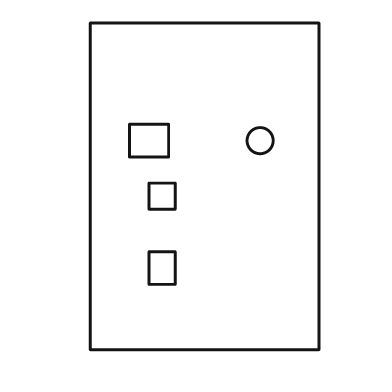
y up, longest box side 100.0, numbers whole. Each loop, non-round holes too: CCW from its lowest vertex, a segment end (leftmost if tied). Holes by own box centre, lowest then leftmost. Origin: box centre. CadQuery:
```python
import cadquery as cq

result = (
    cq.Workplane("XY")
    .moveTo(-35.0, -50.0)
    .lineTo(35.0, -50.0)
    .lineTo(35.0, 50.0)
    .lineTo(-35.0, 50.0)
    .close()
    .moveTo(-17.0, -30.0)
    .lineTo(-9.0, -30.0)
    .lineTo(-9.0, -20.0)
    .lineTo(-17.0, -20.0)
    .close()
    .moveTo(-17.0, -7.0)
    .lineTo(-9.0, -7.0)
    .lineTo(-9.0, 1.0)
    .lineTo(-17.0, 1.0)
    .close()
    .moveTo(-23.0, 9.0)
    .lineTo(-11.0, 9.0)
    .lineTo(-11.0, 19.0)
    .lineTo(-23.0, 19.0)
    .close()
    .moveTo(17.0, 14.0)
    .circle(4.0)
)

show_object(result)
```